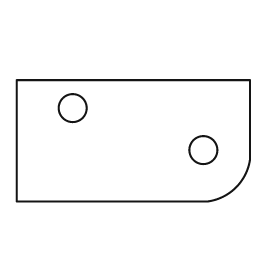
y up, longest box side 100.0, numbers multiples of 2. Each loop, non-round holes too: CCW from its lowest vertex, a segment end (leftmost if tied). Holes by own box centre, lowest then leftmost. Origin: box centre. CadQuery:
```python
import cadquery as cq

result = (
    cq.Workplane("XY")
    .moveTo(-50.0, -26.0)
    .lineTo(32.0, -26.0)
    .threePointArc((44.0, -20.0), (50.0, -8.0))
    .lineTo(50.0, 26.0)
    .lineTo(-50.0, 26.0)
    .close()
    .moveTo(30.0, -4.0)
    .circle(6.0)
    .moveTo(-26.0, 14.0)
    .circle(6.0)
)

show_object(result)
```